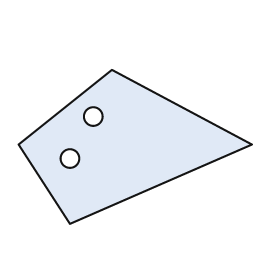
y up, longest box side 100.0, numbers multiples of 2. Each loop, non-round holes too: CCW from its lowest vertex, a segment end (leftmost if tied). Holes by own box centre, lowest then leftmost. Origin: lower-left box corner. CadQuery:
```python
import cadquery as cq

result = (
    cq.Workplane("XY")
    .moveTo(22.0, 0.0)
    .lineTo(100.0, 34.0)
    .lineTo(40.0, 66.0)
    .lineTo(0.0, 34.0)
    .close()
    .moveTo(22.0, 28.0)
    .circle(4.0)
    .moveTo(32.0, 46.0)
    .circle(4.0)
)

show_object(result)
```